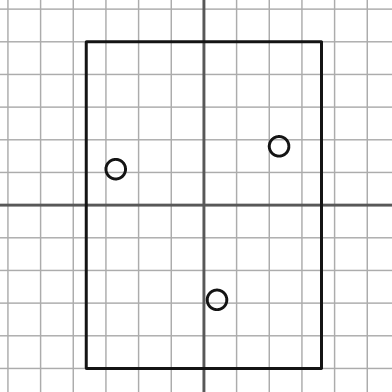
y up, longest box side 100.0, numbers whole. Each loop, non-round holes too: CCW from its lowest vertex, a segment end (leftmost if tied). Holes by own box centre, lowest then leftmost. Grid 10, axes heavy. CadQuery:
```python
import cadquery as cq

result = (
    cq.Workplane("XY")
    .moveTo(-36.0, -50.0)
    .lineTo(36.0, -50.0)
    .lineTo(36.0, 50.0)
    .lineTo(-36.0, 50.0)
    .close()
    .moveTo(4.0, -29.0)
    .circle(3.0)
    .moveTo(-27.0, 11.0)
    .circle(3.0)
    .moveTo(23.0, 18.0)
    .circle(3.0)
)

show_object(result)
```